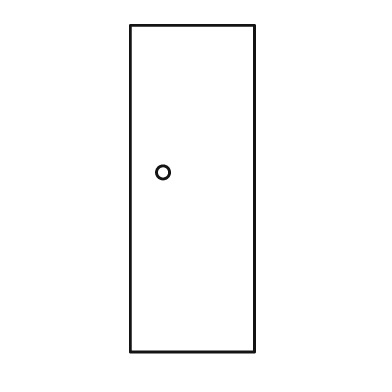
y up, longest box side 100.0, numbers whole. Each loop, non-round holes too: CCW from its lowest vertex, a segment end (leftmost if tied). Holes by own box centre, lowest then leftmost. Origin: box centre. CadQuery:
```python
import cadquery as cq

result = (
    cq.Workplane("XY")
    .moveTo(-19.0, -50.0)
    .lineTo(19.0, -50.0)
    .lineTo(19.0, 50.0)
    .lineTo(-19.0, 50.0)
    .close()
    .moveTo(-9.0, 5.0)
    .circle(2.0)
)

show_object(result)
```